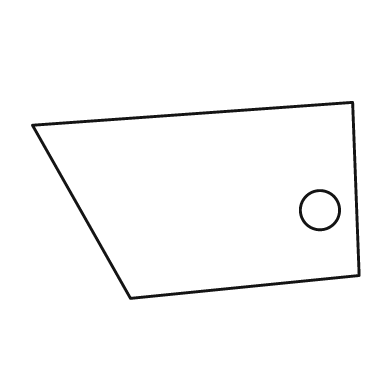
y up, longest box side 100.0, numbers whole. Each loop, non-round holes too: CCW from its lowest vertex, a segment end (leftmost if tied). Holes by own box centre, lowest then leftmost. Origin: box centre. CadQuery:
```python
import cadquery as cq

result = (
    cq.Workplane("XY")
    .moveTo(-20.0, -30.0)
    .lineTo(50.0, -23.0)
    .lineTo(48.0, 30.0)
    .lineTo(-50.0, 23.0)
    .close()
    .moveTo(38.0, -3.0)
    .circle(6.0)
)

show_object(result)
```